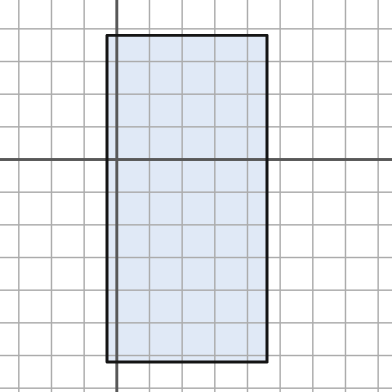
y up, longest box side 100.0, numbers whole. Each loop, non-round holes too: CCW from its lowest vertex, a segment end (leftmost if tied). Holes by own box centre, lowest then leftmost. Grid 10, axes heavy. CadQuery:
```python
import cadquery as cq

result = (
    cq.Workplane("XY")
    .moveTo(-3.0, -62.0)
    .lineTo(46.0, -62.0)
    .lineTo(46.0, 38.0)
    .lineTo(-3.0, 38.0)
    .close()
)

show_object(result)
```